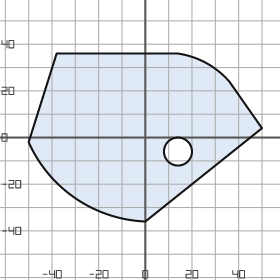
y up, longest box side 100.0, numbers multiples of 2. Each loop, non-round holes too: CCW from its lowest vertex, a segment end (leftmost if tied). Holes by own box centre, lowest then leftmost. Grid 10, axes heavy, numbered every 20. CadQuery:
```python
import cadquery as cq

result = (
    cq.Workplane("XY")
    .moveTo(0.0, -36.0)
    .lineTo(50.0, 4.0)
    .lineTo(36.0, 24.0)
    .threePointArc((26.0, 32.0), (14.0, 36.0))
    .lineTo(-38.0, 36.0)
    .lineTo(-50.0, -2.0)
    .threePointArc((-30.0, -26.0), (0.0, -36.0))
    .close()
    .moveTo(14.0, -6.0)
    .circle(6.0)
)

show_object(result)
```